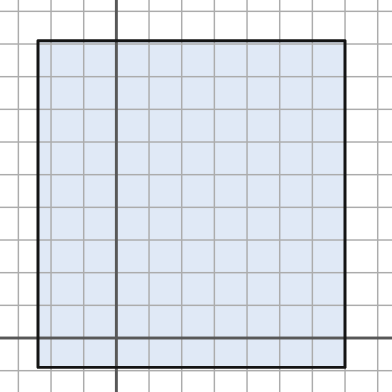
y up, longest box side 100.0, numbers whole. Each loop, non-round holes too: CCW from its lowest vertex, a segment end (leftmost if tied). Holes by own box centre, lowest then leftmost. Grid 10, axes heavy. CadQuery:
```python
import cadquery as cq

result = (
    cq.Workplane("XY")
    .moveTo(-24.0, -9.0)
    .lineTo(70.0, -9.0)
    .lineTo(70.0, 91.0)
    .lineTo(-24.0, 91.0)
    .close()
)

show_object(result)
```